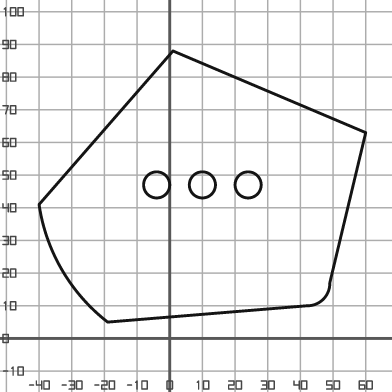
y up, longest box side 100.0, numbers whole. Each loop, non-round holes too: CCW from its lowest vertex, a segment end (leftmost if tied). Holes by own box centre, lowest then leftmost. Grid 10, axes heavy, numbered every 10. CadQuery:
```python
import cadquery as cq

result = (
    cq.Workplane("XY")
    .moveTo(-19.0, 5.0)
    .lineTo(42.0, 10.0)
    .threePointArc((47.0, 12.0), (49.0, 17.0))
    .lineTo(60.0, 63.0)
    .lineTo(1.0, 88.0)
    .lineTo(-40.0, 41.0)
    .threePointArc((-33.0, 21.0), (-19.0, 5.0))
    .close()
    .moveTo(-4.0, 47.0)
    .circle(4.0)
    .moveTo(10.0, 47.0)
    .circle(4.0)
    .moveTo(24.0, 47.0)
    .circle(4.0)
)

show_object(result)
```